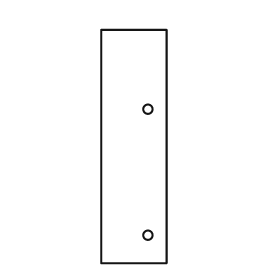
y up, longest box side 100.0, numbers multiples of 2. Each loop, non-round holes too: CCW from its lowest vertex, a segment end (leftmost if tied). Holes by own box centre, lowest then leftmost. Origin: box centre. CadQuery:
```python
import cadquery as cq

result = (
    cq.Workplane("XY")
    .moveTo(-14.0, -50.0)
    .lineTo(14.0, -50.0)
    .lineTo(14.0, 50.0)
    .lineTo(-14.0, 50.0)
    .close()
    .moveTo(6.0, -38.0)
    .circle(2.0)
    .moveTo(6.0, 16.0)
    .circle(2.0)
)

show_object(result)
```